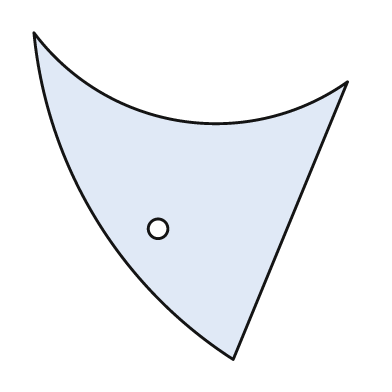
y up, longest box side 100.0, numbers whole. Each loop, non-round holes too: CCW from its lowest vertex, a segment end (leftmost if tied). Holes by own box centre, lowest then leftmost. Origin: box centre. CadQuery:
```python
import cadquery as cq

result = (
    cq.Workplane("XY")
    .moveTo(13.0, -50.0)
    .lineTo(48.0, 35.0)
    .threePointArc((-3.0, 23.0), (-48.0, 50.0))
    .threePointArc((-29.0, -7.0), (13.0, -50.0))
    .close()
    .moveTo(-10.0, -10.0)
    .circle(3.0)
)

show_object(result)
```